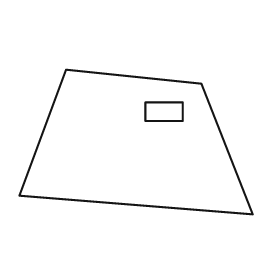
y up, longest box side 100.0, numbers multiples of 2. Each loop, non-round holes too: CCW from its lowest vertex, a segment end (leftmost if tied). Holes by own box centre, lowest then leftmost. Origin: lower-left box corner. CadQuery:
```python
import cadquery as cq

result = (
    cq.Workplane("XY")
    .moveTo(100.0, 0.0)
    .lineTo(78.0, 56.0)
    .lineTo(20.0, 62.0)
    .lineTo(0.0, 8.0)
    .close()
    .moveTo(54.0, 40.0)
    .lineTo(70.0, 40.0)
    .lineTo(70.0, 48.0)
    .lineTo(54.0, 48.0)
    .close()
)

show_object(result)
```